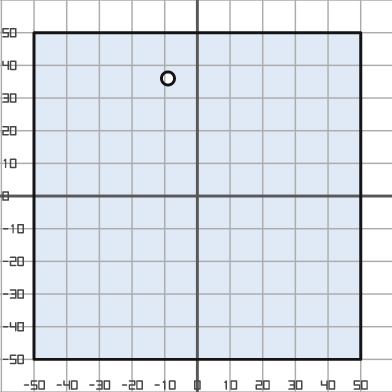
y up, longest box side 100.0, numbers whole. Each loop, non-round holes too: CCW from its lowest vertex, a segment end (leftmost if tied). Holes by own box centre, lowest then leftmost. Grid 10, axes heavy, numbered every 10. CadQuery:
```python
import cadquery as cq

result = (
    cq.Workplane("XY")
    .moveTo(-50.0, -50.0)
    .lineTo(50.0, -50.0)
    .lineTo(50.0, 50.0)
    .lineTo(-50.0, 50.0)
    .close()
    .moveTo(-9.0, 36.0)
    .circle(2.0)
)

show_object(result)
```